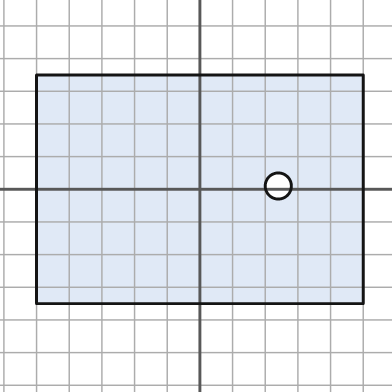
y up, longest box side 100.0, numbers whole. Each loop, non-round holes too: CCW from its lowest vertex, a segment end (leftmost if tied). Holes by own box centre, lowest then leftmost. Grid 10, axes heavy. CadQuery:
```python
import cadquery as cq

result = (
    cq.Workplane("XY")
    .moveTo(-50.0, -35.0)
    .lineTo(50.0, -35.0)
    .lineTo(50.0, 35.0)
    .lineTo(-50.0, 35.0)
    .close()
    .moveTo(24.0, 1.0)
    .circle(4.0)
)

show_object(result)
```